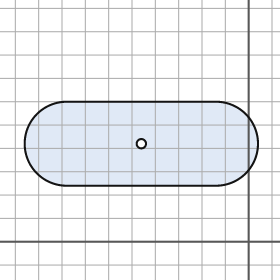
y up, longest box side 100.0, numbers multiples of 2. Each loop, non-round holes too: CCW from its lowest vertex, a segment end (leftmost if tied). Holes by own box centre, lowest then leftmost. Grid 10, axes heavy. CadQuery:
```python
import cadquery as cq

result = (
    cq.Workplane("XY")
    .moveTo(-78.0, 24.0)
    .lineTo(-14.0, 24.0)
    .threePointArc((4.0, 42.0), (-14.0, 60.0))
    .lineTo(-78.0, 60.0)
    .threePointArc((-96.0, 42.0), (-78.0, 24.0))
    .close()
    .moveTo(-46.0, 42.0)
    .circle(2.0)
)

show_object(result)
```